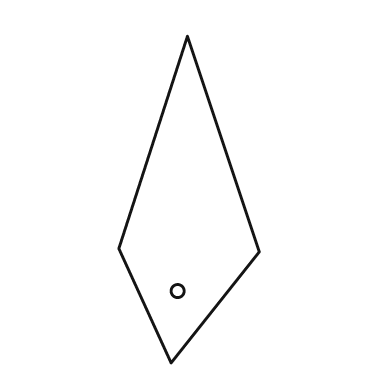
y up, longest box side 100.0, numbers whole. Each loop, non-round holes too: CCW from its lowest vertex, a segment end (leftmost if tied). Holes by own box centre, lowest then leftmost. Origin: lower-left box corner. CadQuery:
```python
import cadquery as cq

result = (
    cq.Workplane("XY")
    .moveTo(16.0, 0.0)
    .lineTo(43.0, 34.0)
    .lineTo(21.0, 100.0)
    .lineTo(0.0, 35.0)
    .close()
    .moveTo(18.0, 22.0)
    .circle(2.0)
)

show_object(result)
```